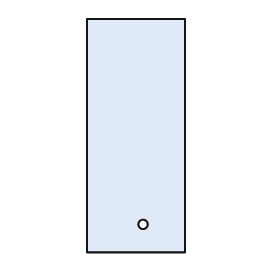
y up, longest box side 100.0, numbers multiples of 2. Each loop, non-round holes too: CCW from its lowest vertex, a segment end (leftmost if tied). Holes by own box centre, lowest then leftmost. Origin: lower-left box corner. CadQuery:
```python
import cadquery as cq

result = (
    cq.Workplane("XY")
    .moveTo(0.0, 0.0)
    .lineTo(42.0, 0.0)
    .lineTo(42.0, 100.0)
    .lineTo(0.0, 100.0)
    .close()
    .moveTo(24.0, 12.0)
    .circle(2.0)
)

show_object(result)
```